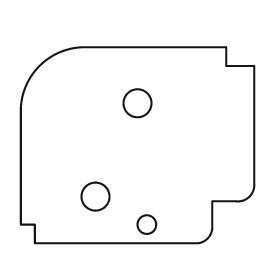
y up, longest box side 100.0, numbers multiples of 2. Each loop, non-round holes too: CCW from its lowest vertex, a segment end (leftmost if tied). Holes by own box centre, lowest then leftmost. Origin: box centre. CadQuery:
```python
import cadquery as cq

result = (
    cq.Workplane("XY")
    .moveTo(-44.0, -42.0)
    .lineTo(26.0, -42.0)
    .threePointArc((30.0, -40.0), (32.0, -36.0))
    .lineTo(32.0, -24.0)
    .lineTo(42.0, -24.0)
    .threePointArc((48.0, -22.0), (50.0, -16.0))
    .lineTo(50.0, 34.0)
    .lineTo(38.0, 34.0)
    .lineTo(38.0, 42.0)
    .lineTo(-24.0, 42.0)
    .threePointArc((-42.0, 34.0), (-50.0, 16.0))
    .lineTo(-50.0, -34.0)
    .lineTo(-44.0, -34.0)
    .close()
    .moveTo(4.0, -34.0)
    .circle(4.0)
    .moveTo(-18.0, -22.0)
    .circle(6.0)
    .moveTo(0.0, 18.0)
    .circle(6.0)
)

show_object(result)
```